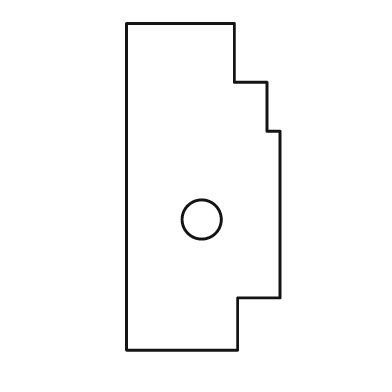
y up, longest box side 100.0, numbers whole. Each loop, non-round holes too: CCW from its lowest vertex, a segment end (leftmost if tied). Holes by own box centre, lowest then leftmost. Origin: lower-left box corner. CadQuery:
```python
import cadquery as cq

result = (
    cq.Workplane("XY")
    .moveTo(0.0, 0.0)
    .lineTo(34.0, 0.0)
    .lineTo(34.0, 16.0)
    .lineTo(47.0, 16.0)
    .lineTo(47.0, 67.0)
    .lineTo(43.0, 67.0)
    .lineTo(43.0, 82.0)
    .lineTo(33.0, 82.0)
    .lineTo(33.0, 100.0)
    .lineTo(0.0, 100.0)
    .close()
    .moveTo(23.0, 40.0)
    .circle(6.0)
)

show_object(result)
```